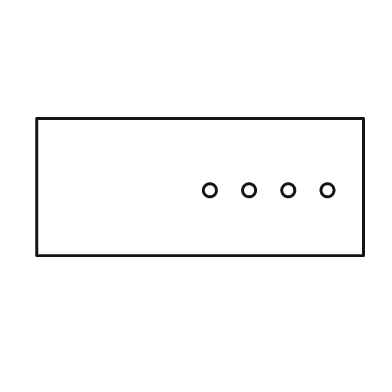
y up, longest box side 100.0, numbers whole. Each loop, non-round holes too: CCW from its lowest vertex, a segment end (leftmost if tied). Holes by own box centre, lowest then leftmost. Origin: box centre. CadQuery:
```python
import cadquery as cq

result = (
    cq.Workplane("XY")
    .moveTo(-50.0, -21.0)
    .lineTo(50.0, -21.0)
    .lineTo(50.0, 21.0)
    .lineTo(-50.0, 21.0)
    .close()
    .moveTo(3.0, -1.0)
    .circle(2.0)
    .moveTo(15.0, -1.0)
    .circle(2.0)
    .moveTo(27.0, -1.0)
    .circle(2.0)
    .moveTo(39.0, -1.0)
    .circle(2.0)
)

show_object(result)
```